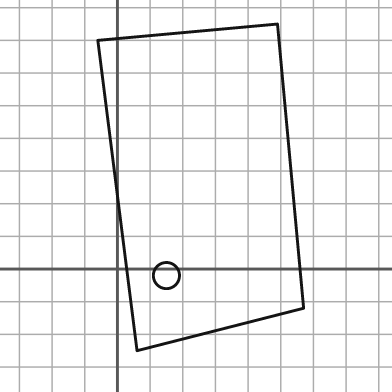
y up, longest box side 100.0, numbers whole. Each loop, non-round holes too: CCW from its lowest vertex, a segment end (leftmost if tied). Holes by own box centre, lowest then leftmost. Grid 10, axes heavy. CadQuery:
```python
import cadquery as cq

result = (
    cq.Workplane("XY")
    .moveTo(6.0, -25.0)
    .lineTo(57.0, -12.0)
    .lineTo(49.0, 75.0)
    .lineTo(-6.0, 70.0)
    .close()
    .moveTo(15.0, -2.0)
    .circle(4.0)
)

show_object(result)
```